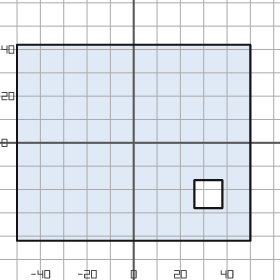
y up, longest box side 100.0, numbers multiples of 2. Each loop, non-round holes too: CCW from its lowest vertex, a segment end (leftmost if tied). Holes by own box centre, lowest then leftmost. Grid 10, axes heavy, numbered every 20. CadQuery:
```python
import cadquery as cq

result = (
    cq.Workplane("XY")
    .moveTo(-50.0, -42.0)
    .lineTo(50.0, -42.0)
    .lineTo(50.0, 42.0)
    .lineTo(-50.0, 42.0)
    .close()
    .moveTo(26.0, -28.0)
    .lineTo(38.0, -28.0)
    .lineTo(38.0, -16.0)
    .lineTo(26.0, -16.0)
    .close()
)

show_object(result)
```